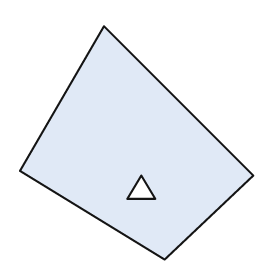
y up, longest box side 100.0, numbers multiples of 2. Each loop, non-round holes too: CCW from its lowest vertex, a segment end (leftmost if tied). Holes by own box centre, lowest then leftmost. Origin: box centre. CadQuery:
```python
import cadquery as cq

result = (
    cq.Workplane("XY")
    .moveTo(12.0, -50.0)
    .lineTo(50.0, -14.0)
    .lineTo(-14.0, 50.0)
    .lineTo(-50.0, -12.0)
    .close()
    .moveTo(-4.0, -24.0)
    .lineTo(8.0, -24.0)
    .lineTo(2.0, -14.0)
    .close()
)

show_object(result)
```